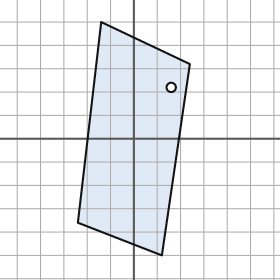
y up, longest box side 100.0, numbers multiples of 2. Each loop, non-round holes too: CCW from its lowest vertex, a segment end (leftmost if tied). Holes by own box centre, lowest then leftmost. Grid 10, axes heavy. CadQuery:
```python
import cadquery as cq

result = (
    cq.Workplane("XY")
    .moveTo(12.0, -50.0)
    .lineTo(24.0, 32.0)
    .lineTo(-14.0, 50.0)
    .lineTo(-24.0, -36.0)
    .close()
    .moveTo(16.0, 22.0)
    .circle(2.0)
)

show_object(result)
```